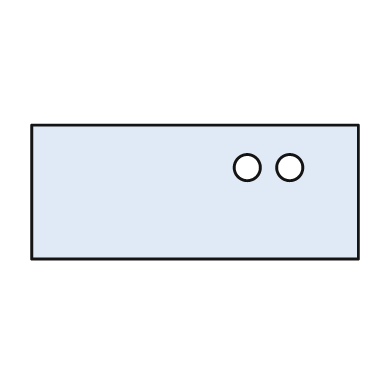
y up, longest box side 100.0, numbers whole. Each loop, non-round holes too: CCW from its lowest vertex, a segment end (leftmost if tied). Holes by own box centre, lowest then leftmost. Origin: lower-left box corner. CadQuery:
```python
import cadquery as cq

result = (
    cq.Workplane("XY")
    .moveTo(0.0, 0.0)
    .lineTo(100.0, 0.0)
    .lineTo(100.0, 41.0)
    .lineTo(0.0, 41.0)
    .close()
    .moveTo(66.0, 28.0)
    .circle(4.0)
    .moveTo(79.0, 28.0)
    .circle(4.0)
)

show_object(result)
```